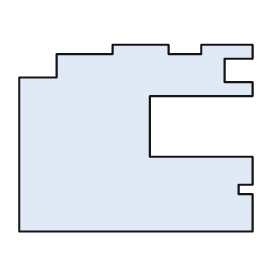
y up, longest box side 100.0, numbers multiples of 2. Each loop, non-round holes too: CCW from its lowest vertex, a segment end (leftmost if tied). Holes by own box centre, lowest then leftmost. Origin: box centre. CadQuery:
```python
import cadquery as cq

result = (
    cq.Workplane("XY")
    .moveTo(-50.0, -40.0)
    .lineTo(50.0, -40.0)
    .lineTo(50.0, -24.0)
    .lineTo(44.0, -24.0)
    .lineTo(44.0, -20.0)
    .lineTo(50.0, -20.0)
    .lineTo(50.0, -8.0)
    .lineTo(6.0, -8.0)
    .lineTo(6.0, 18.0)
    .lineTo(50.0, 18.0)
    .lineTo(50.0, 24.0)
    .lineTo(38.0, 24.0)
    .lineTo(38.0, 34.0)
    .lineTo(50.0, 34.0)
    .lineTo(50.0, 40.0)
    .lineTo(28.0, 40.0)
    .lineTo(28.0, 36.0)
    .lineTo(14.0, 36.0)
    .lineTo(14.0, 40.0)
    .lineTo(-10.0, 40.0)
    .lineTo(-10.0, 36.0)
    .lineTo(-34.0, 36.0)
    .lineTo(-34.0, 26.0)
    .lineTo(-50.0, 26.0)
    .close()
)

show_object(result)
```